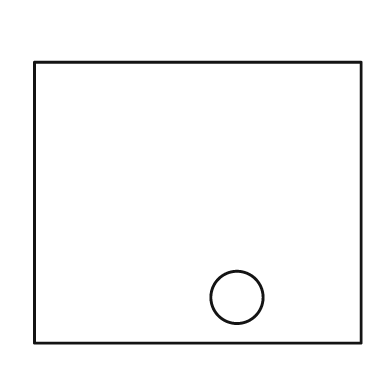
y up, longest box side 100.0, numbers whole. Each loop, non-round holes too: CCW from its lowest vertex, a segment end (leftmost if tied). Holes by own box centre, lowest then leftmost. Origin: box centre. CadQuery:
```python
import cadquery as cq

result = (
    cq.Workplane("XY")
    .moveTo(-50.0, -43.0)
    .lineTo(50.0, -43.0)
    .lineTo(50.0, 43.0)
    .lineTo(-50.0, 43.0)
    .close()
    .moveTo(12.0, -29.0)
    .circle(8.0)
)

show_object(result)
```